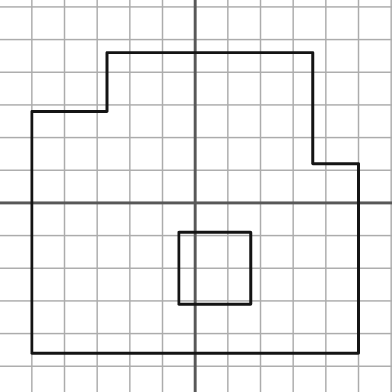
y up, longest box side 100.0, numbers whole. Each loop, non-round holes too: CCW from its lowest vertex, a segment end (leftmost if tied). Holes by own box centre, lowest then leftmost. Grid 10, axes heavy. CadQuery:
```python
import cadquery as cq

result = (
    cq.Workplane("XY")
    .moveTo(-50.0, -46.0)
    .lineTo(50.0, -46.0)
    .lineTo(50.0, 12.0)
    .lineTo(36.0, 12.0)
    .lineTo(36.0, 46.0)
    .lineTo(-27.0, 46.0)
    .lineTo(-27.0, 28.0)
    .lineTo(-50.0, 28.0)
    .close()
    .moveTo(-5.0, -31.0)
    .lineTo(17.0, -31.0)
    .lineTo(17.0, -9.0)
    .lineTo(-5.0, -9.0)
    .close()
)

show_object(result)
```